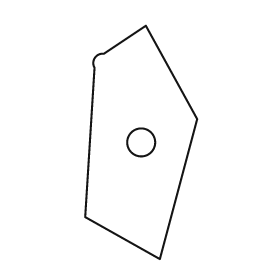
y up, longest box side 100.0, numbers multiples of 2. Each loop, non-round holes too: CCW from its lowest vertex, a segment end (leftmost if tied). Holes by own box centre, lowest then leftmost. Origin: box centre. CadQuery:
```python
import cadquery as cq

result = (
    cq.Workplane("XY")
    .moveTo(8.0, -50.0)
    .lineTo(24.0, 10.0)
    .lineTo(2.0, 50.0)
    .lineTo(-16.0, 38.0)
    .threePointArc((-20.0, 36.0), (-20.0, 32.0))
    .lineTo(-24.0, -32.0)
    .close()
    .moveTo(0.0, 0.0)
    .circle(6.0)
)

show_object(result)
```